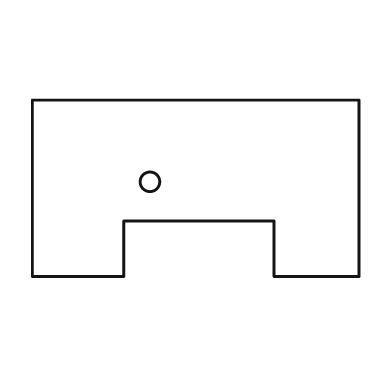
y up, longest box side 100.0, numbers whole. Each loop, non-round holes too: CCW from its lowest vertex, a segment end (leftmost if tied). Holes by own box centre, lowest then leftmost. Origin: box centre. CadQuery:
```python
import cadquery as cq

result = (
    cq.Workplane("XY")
    .moveTo(-50.0, -27.0)
    .lineTo(-22.0, -27.0)
    .lineTo(-22.0, -10.0)
    .lineTo(24.0, -10.0)
    .lineTo(24.0, -27.0)
    .lineTo(50.0, -27.0)
    .lineTo(50.0, 27.0)
    .lineTo(-50.0, 27.0)
    .close()
    .moveTo(-14.0, 2.0)
    .circle(3.0)
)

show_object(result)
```